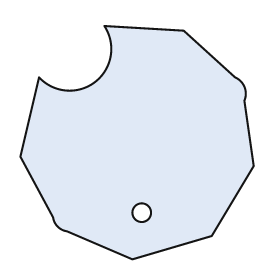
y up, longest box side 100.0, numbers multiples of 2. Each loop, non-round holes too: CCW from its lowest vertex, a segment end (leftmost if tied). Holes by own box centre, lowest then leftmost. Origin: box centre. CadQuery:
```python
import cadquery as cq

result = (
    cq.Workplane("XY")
    .moveTo(-2.0, -50.0)
    .lineTo(32.0, -40.0)
    .lineTo(50.0, -10.0)
    .lineTo(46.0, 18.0)
    .threePointArc((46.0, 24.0), (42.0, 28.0))
    .lineTo(20.0, 48.0)
    .lineTo(-14.0, 50.0)
    .threePointArc((-18.0, 26.0), (-42.0, 28.0))
    .lineTo(-50.0, -6.0)
    .lineTo(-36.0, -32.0)
    .threePointArc((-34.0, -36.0), (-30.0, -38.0))
    .close()
    .moveTo(2.0, -30.0)
    .circle(4.0)
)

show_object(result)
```